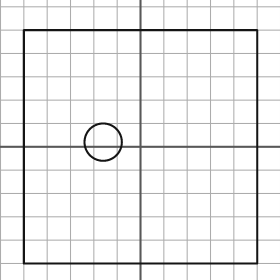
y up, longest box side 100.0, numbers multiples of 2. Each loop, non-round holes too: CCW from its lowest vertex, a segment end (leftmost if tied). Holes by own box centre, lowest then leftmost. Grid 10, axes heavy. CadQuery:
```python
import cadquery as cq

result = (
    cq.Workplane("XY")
    .moveTo(-50.0, -50.0)
    .lineTo(50.0, -50.0)
    .lineTo(50.0, 50.0)
    .lineTo(-50.0, 50.0)
    .close()
    .moveTo(-16.0, 2.0)
    .circle(8.0)
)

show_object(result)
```